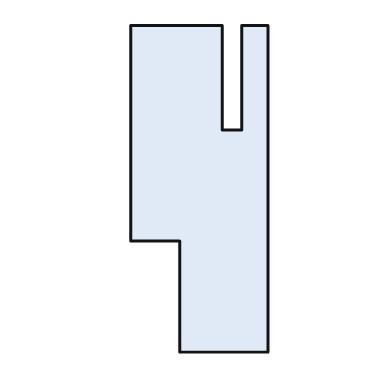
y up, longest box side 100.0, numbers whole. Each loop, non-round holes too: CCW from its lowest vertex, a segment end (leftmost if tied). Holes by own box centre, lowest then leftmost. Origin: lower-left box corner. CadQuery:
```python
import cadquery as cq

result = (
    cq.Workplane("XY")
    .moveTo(15.0, 0.0)
    .lineTo(42.0, 0.0)
    .lineTo(42.0, 100.0)
    .lineTo(34.0, 100.0)
    .lineTo(34.0, 68.0)
    .lineTo(28.0, 68.0)
    .lineTo(28.0, 100.0)
    .lineTo(0.0, 100.0)
    .lineTo(0.0, 34.0)
    .lineTo(15.0, 34.0)
    .close()
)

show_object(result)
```